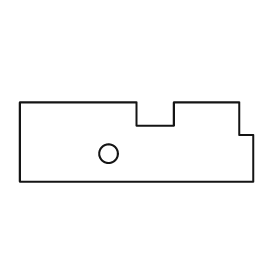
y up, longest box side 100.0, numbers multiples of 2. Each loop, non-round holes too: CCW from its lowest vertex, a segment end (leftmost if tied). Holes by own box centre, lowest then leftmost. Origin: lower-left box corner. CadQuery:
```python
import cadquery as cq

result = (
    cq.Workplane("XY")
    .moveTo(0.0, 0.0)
    .lineTo(100.0, 0.0)
    .lineTo(100.0, 20.0)
    .lineTo(94.0, 20.0)
    .lineTo(94.0, 34.0)
    .lineTo(66.0, 34.0)
    .lineTo(66.0, 24.0)
    .lineTo(50.0, 24.0)
    .lineTo(50.0, 34.0)
    .lineTo(0.0, 34.0)
    .close()
    .moveTo(38.0, 12.0)
    .circle(4.0)
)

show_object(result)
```